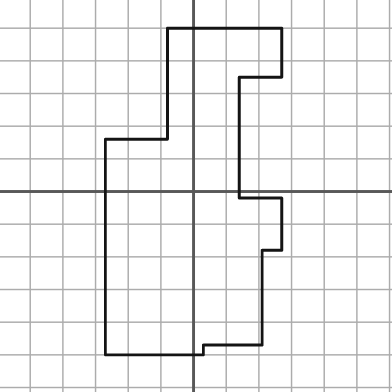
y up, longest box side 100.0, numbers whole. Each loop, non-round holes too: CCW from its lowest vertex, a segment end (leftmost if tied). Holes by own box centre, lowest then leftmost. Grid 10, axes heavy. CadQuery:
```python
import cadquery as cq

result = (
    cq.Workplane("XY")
    .moveTo(-27.0, -50.0)
    .lineTo(3.0, -50.0)
    .lineTo(3.0, -47.0)
    .lineTo(21.0, -47.0)
    .lineTo(21.0, -18.0)
    .lineTo(27.0, -18.0)
    .lineTo(27.0, -2.0)
    .lineTo(14.0, -2.0)
    .lineTo(14.0, 35.0)
    .lineTo(27.0, 35.0)
    .lineTo(27.0, 50.0)
    .lineTo(-8.0, 50.0)
    .lineTo(-8.0, 16.0)
    .lineTo(-27.0, 16.0)
    .close()
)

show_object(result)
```